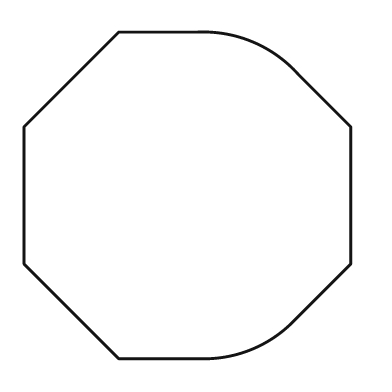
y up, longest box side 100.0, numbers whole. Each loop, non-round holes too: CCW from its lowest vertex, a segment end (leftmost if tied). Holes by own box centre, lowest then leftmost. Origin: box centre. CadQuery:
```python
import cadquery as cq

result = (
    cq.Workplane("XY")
    .moveTo(-21.0, -50.0)
    .lineTo(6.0, -50.0)
    .threePointArc((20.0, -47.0), (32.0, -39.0))
    .lineTo(50.0, -21.0)
    .lineTo(50.0, 21.0)
    .lineTo(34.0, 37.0)
    .threePointArc((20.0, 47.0), (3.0, 50.0))
    .lineTo(-21.0, 50.0)
    .lineTo(-50.0, 21.0)
    .lineTo(-50.0, -21.0)
    .close()
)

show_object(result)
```